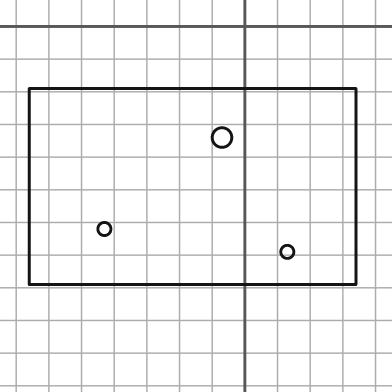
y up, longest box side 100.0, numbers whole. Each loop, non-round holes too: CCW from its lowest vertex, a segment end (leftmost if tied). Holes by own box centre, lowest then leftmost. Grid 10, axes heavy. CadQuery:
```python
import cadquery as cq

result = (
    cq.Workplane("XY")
    .moveTo(-66.0, -79.0)
    .lineTo(34.0, -79.0)
    .lineTo(34.0, -19.0)
    .lineTo(-66.0, -19.0)
    .close()
    .moveTo(13.0, -69.0)
    .circle(2.0)
    .moveTo(-43.0, -62.0)
    .circle(2.0)
    .moveTo(-7.0, -34.0)
    .circle(3.0)
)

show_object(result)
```